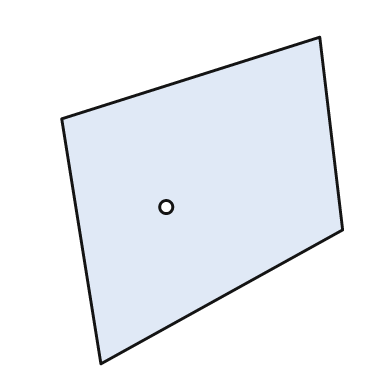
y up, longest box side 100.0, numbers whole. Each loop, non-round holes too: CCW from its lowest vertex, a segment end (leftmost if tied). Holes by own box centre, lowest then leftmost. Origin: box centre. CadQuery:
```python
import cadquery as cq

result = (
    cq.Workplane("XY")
    .moveTo(-31.0, -50.0)
    .lineTo(43.0, -9.0)
    .lineTo(36.0, 50.0)
    .lineTo(-43.0, 25.0)
    .close()
    .moveTo(-11.0, -2.0)
    .circle(2.0)
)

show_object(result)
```